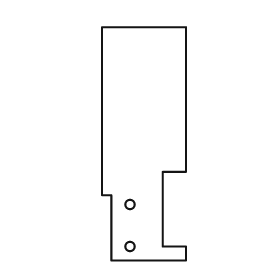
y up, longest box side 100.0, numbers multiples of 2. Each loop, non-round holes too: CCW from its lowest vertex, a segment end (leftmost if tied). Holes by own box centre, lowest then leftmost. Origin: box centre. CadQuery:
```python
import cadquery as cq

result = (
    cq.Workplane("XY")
    .moveTo(-14.0, -50.0)
    .lineTo(18.0, -50.0)
    .lineTo(18.0, -44.0)
    .lineTo(8.0, -44.0)
    .lineTo(8.0, -12.0)
    .lineTo(18.0, -12.0)
    .lineTo(18.0, 50.0)
    .lineTo(-18.0, 50.0)
    .lineTo(-18.0, -22.0)
    .lineTo(-14.0, -22.0)
    .close()
    .moveTo(-6.0, -44.0)
    .circle(2.0)
    .moveTo(-6.0, -26.0)
    .circle(2.0)
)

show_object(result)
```